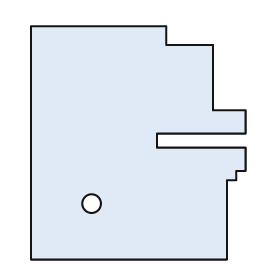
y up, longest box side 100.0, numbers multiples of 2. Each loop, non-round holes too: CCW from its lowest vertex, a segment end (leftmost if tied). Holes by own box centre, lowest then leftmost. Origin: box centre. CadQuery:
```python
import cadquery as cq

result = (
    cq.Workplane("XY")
    .moveTo(-46.0, -50.0)
    .lineTo(38.0, -50.0)
    .lineTo(38.0, -16.0)
    .lineTo(42.0, -16.0)
    .lineTo(42.0, -12.0)
    .lineTo(46.0, -12.0)
    .lineTo(46.0, -2.0)
    .lineTo(8.0, -2.0)
    .lineTo(8.0, 4.0)
    .lineTo(46.0, 4.0)
    .lineTo(46.0, 14.0)
    .lineTo(32.0, 14.0)
    .lineTo(32.0, 42.0)
    .lineTo(12.0, 42.0)
    .lineTo(12.0, 50.0)
    .lineTo(-46.0, 50.0)
    .close()
    .moveTo(-20.0, -26.0)
    .circle(4.0)
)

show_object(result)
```